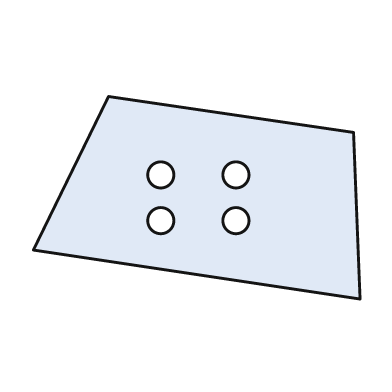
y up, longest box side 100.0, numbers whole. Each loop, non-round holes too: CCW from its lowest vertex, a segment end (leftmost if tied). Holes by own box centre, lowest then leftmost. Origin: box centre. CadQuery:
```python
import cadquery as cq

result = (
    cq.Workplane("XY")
    .moveTo(50.0, -31.0)
    .lineTo(48.0, 20.0)
    .lineTo(-27.0, 31.0)
    .lineTo(-50.0, -16.0)
    .close()
    .moveTo(-11.0, -7.0)
    .circle(4.0)
    .moveTo(12.0, -7.0)
    .circle(4.0)
    .moveTo(-11.0, 7.0)
    .circle(4.0)
    .moveTo(12.0, 7.0)
    .circle(4.0)
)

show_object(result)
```